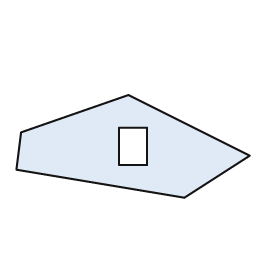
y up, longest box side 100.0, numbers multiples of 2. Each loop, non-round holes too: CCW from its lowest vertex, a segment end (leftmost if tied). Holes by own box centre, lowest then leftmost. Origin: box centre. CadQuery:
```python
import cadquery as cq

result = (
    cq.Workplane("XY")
    .moveTo(22.0, -22.0)
    .lineTo(50.0, -4.0)
    .lineTo(-2.0, 22.0)
    .lineTo(-48.0, 6.0)
    .lineTo(-50.0, -10.0)
    .close()
    .moveTo(-6.0, -8.0)
    .lineTo(6.0, -8.0)
    .lineTo(6.0, 8.0)
    .lineTo(-6.0, 8.0)
    .close()
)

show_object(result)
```